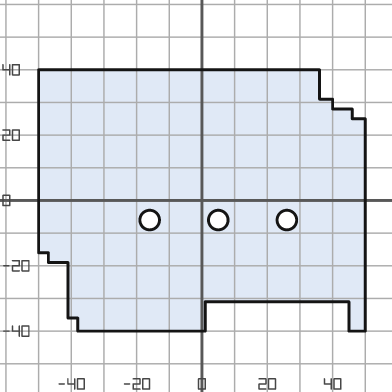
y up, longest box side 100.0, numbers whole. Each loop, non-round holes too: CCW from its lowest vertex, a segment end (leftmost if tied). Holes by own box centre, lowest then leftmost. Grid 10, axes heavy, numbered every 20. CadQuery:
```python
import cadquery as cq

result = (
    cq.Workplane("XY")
    .moveTo(-38.0, -40.0)
    .lineTo(1.0, -40.0)
    .lineTo(1.0, -31.0)
    .lineTo(45.0, -31.0)
    .lineTo(45.0, -40.0)
    .lineTo(50.0, -40.0)
    .lineTo(50.0, 25.0)
    .lineTo(46.0, 25.0)
    .lineTo(46.0, 28.0)
    .lineTo(40.0, 28.0)
    .lineTo(40.0, 31.0)
    .lineTo(36.0, 31.0)
    .lineTo(36.0, 40.0)
    .lineTo(-50.0, 40.0)
    .lineTo(-50.0, -16.0)
    .lineTo(-47.0, -16.0)
    .lineTo(-47.0, -19.0)
    .lineTo(-41.0, -19.0)
    .lineTo(-41.0, -36.0)
    .lineTo(-38.0, -36.0)
    .close()
    .moveTo(-16.0, -6.0)
    .circle(3.0)
    .moveTo(5.0, -6.0)
    .circle(3.0)
    .moveTo(26.0, -6.0)
    .circle(3.0)
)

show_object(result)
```